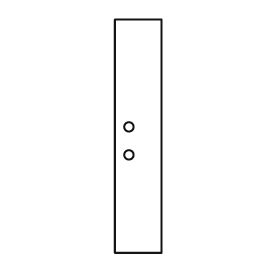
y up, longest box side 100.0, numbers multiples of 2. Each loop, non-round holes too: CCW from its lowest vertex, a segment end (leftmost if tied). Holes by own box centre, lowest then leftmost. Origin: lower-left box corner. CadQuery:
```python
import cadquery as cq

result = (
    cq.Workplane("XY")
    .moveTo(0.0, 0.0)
    .lineTo(20.0, 0.0)
    .lineTo(20.0, 100.0)
    .lineTo(0.0, 100.0)
    .close()
    .moveTo(6.0, 42.0)
    .circle(2.0)
    .moveTo(6.0, 54.0)
    .circle(2.0)
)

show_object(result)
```